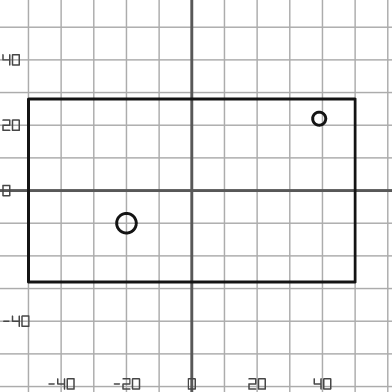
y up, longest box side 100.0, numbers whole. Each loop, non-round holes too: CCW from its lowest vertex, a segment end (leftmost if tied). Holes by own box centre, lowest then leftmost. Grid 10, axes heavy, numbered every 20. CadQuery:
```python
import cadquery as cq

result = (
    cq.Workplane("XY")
    .moveTo(-50.0, -28.0)
    .lineTo(50.0, -28.0)
    .lineTo(50.0, 28.0)
    .lineTo(-50.0, 28.0)
    .close()
    .moveTo(-20.0, -10.0)
    .circle(3.0)
    .moveTo(39.0, 22.0)
    .circle(2.0)
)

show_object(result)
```